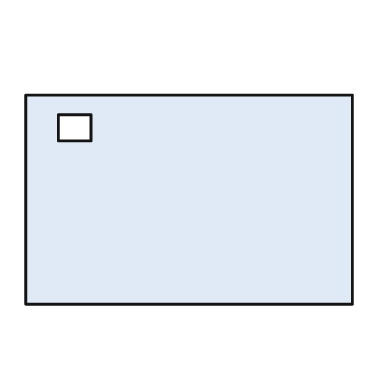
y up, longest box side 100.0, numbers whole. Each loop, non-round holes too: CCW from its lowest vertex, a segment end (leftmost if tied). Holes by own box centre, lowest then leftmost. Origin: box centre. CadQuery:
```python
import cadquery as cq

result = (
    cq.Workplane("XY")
    .moveTo(-50.0, -32.0)
    .lineTo(50.0, -32.0)
    .lineTo(50.0, 32.0)
    .lineTo(-50.0, 32.0)
    .close()
    .moveTo(-40.0, 18.0)
    .lineTo(-30.0, 18.0)
    .lineTo(-30.0, 26.0)
    .lineTo(-40.0, 26.0)
    .close()
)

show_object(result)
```